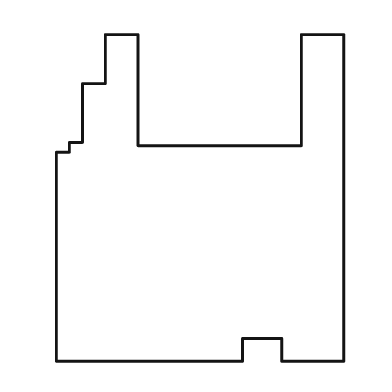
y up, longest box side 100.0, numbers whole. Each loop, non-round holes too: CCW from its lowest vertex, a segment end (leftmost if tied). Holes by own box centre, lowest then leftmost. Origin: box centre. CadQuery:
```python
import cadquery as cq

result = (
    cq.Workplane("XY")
    .moveTo(-44.0, -50.0)
    .lineTo(13.0, -50.0)
    .lineTo(13.0, -43.0)
    .lineTo(25.0, -43.0)
    .lineTo(25.0, -50.0)
    .lineTo(44.0, -50.0)
    .lineTo(44.0, 50.0)
    .lineTo(31.0, 50.0)
    .lineTo(31.0, 16.0)
    .lineTo(-19.0, 16.0)
    .lineTo(-19.0, 50.0)
    .lineTo(-29.0, 50.0)
    .lineTo(-29.0, 35.0)
    .lineTo(-36.0, 35.0)
    .lineTo(-36.0, 17.0)
    .lineTo(-40.0, 17.0)
    .lineTo(-40.0, 14.0)
    .lineTo(-44.0, 14.0)
    .close()
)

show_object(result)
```